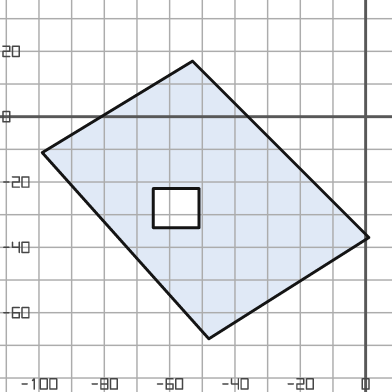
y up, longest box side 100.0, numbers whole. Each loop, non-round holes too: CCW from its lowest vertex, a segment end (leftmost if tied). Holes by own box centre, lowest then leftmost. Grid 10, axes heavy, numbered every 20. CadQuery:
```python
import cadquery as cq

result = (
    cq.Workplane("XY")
    .moveTo(-48.0, -68.0)
    .lineTo(1.0, -37.0)
    .lineTo(-53.0, 17.0)
    .lineTo(-99.0, -11.0)
    .close()
    .moveTo(-65.0, -34.0)
    .lineTo(-51.0, -34.0)
    .lineTo(-51.0, -22.0)
    .lineTo(-65.0, -22.0)
    .close()
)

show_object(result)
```